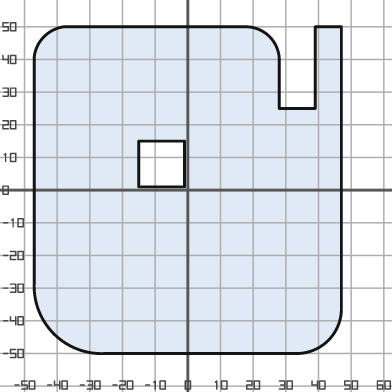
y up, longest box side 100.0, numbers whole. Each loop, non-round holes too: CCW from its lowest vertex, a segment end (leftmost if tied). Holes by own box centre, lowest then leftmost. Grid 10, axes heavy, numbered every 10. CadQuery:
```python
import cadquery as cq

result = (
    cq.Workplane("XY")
    .moveTo(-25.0, -50.0)
    .lineTo(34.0, -50.0)
    .threePointArc((43.0, -46.0), (47.0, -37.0))
    .lineTo(47.0, 50.0)
    .lineTo(39.0, 50.0)
    .lineTo(39.0, 25.0)
    .lineTo(28.0, 25.0)
    .lineTo(28.0, 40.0)
    .threePointArc((25.0, 47.0), (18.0, 50.0))
    .lineTo(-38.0, 50.0)
    .threePointArc((-44.0, 47.0), (-47.0, 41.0))
    .lineTo(-47.0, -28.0)
    .threePointArc((-41.0, -44.0), (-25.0, -50.0))
    .close()
    .moveTo(-15.0, 1.0)
    .lineTo(-1.0, 1.0)
    .lineTo(-1.0, 15.0)
    .lineTo(-15.0, 15.0)
    .close()
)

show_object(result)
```